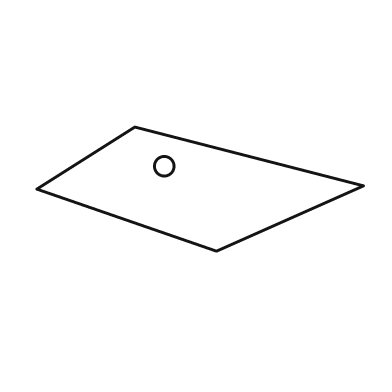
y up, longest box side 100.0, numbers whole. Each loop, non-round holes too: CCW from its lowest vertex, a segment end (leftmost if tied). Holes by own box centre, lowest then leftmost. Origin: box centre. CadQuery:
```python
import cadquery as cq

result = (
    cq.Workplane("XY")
    .moveTo(5.0, -19.0)
    .lineTo(50.0, 1.0)
    .lineTo(-20.0, 19.0)
    .lineTo(-50.0, 0.0)
    .close()
    .moveTo(-11.0, 7.0)
    .circle(3.0)
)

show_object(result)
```